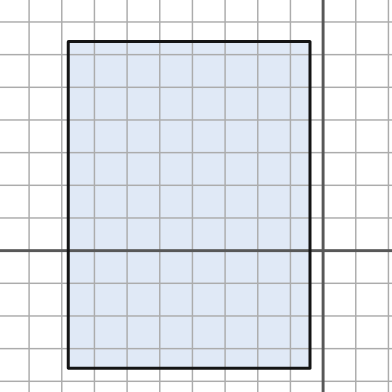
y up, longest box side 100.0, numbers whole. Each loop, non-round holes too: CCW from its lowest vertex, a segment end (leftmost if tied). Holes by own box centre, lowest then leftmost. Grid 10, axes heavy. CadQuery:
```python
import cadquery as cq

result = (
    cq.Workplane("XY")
    .moveTo(-78.0, -36.0)
    .lineTo(-4.0, -36.0)
    .lineTo(-4.0, 64.0)
    .lineTo(-78.0, 64.0)
    .close()
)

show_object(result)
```